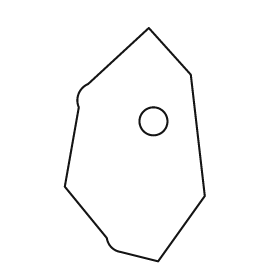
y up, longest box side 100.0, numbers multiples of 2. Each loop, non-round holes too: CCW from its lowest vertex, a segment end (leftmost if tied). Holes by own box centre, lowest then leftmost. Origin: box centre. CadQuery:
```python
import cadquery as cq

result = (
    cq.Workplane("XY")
    .moveTo(10.0, -50.0)
    .lineTo(30.0, -22.0)
    .lineTo(24.0, 30.0)
    .lineTo(6.0, 50.0)
    .lineTo(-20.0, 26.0)
    .threePointArc((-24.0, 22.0), (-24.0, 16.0))
    .lineTo(-30.0, -18.0)
    .lineTo(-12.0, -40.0)
    .threePointArc((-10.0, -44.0), (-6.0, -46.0))
    .close()
    .moveTo(8.0, 10.0)
    .circle(6.0)
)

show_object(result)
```